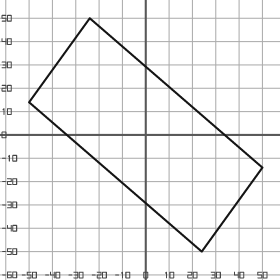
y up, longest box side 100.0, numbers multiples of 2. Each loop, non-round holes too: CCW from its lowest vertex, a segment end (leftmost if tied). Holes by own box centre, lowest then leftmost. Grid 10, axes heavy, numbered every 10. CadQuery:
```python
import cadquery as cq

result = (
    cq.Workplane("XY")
    .moveTo(24.0, -50.0)
    .lineTo(50.0, -14.0)
    .lineTo(-24.0, 50.0)
    .lineTo(-50.0, 14.0)
    .close()
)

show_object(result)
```